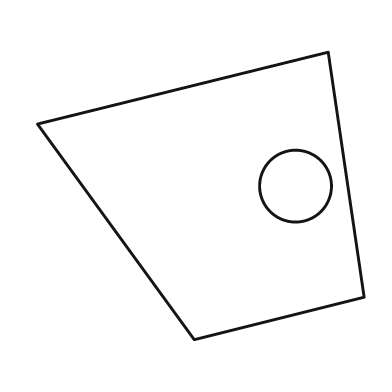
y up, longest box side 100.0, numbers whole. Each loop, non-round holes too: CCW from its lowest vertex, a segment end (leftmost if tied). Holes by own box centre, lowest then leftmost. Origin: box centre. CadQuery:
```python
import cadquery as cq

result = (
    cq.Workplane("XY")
    .moveTo(-2.0, -44.0)
    .lineTo(50.0, -31.0)
    .lineTo(39.0, 44.0)
    .lineTo(-50.0, 22.0)
    .close()
    .moveTo(29.0, 3.0)
    .circle(11.0)
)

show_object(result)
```